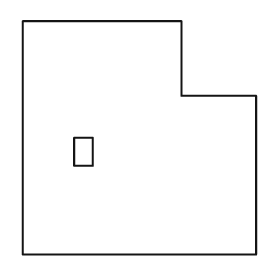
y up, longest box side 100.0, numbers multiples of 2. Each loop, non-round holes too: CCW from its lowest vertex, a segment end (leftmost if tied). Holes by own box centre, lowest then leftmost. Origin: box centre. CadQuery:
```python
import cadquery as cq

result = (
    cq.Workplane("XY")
    .moveTo(-50.0, -50.0)
    .lineTo(50.0, -50.0)
    .lineTo(50.0, 18.0)
    .lineTo(18.0, 18.0)
    .lineTo(18.0, 50.0)
    .lineTo(-50.0, 50.0)
    .close()
    .moveTo(-28.0, -12.0)
    .lineTo(-20.0, -12.0)
    .lineTo(-20.0, 0.0)
    .lineTo(-28.0, 0.0)
    .close()
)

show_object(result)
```